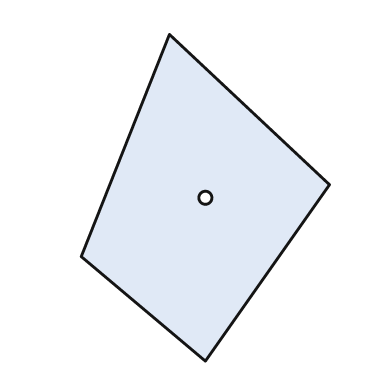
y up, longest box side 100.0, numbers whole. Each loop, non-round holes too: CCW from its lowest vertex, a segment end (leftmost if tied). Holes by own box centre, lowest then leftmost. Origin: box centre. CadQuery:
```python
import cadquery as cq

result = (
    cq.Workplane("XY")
    .moveTo(0.0, -50.0)
    .lineTo(38.0, 4.0)
    .lineTo(-11.0, 50.0)
    .lineTo(-38.0, -18.0)
    .close()
    .moveTo(0.0, 0.0)
    .circle(2.0)
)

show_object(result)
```